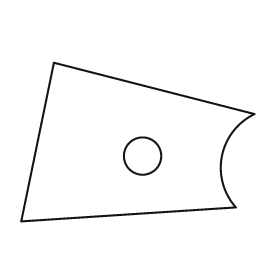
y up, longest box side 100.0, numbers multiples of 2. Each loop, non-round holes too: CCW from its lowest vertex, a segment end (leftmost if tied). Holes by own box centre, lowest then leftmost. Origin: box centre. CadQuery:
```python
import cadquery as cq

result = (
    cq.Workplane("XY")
    .moveTo(-50.0, -34.0)
    .lineTo(42.0, -28.0)
    .threePointArc((36.0, -6.0), (50.0, 12.0))
    .lineTo(-36.0, 34.0)
    .close()
    .moveTo(2.0, -6.0)
    .circle(8.0)
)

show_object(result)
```